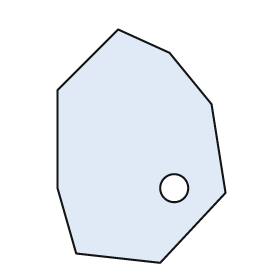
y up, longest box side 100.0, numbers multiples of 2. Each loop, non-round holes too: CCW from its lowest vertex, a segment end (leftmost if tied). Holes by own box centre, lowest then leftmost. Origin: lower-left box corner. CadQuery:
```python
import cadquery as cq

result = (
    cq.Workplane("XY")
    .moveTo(44.0, 0.0)
    .lineTo(72.0, 30.0)
    .lineTo(66.0, 68.0)
    .lineTo(48.0, 90.0)
    .lineTo(26.0, 100.0)
    .lineTo(0.0, 74.0)
    .lineTo(0.0, 32.0)
    .lineTo(8.0, 4.0)
    .close()
    .moveTo(50.0, 32.0)
    .circle(6.0)
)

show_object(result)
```